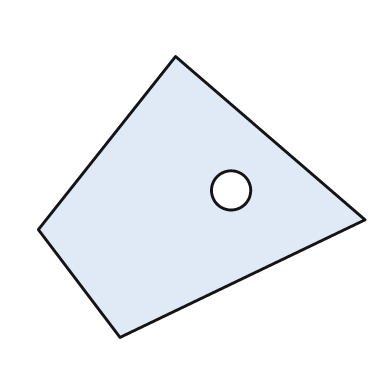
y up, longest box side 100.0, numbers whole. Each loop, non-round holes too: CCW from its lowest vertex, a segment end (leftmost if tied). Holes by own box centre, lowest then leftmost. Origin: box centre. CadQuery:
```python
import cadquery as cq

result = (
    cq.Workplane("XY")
    .moveTo(-25.0, -43.0)
    .lineTo(50.0, -7.0)
    .lineTo(-8.0, 43.0)
    .lineTo(-50.0, -10.0)
    .close()
    .moveTo(9.0, 2.0)
    .circle(6.0)
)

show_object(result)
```